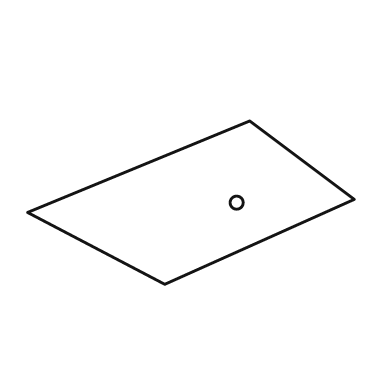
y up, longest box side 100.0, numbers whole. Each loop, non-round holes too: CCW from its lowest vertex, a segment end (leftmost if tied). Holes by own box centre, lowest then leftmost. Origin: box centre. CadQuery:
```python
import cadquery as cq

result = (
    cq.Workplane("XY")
    .moveTo(-8.0, -25.0)
    .lineTo(50.0, 1.0)
    .lineTo(18.0, 25.0)
    .lineTo(-50.0, -3.0)
    .close()
    .moveTo(14.0, 0.0)
    .circle(2.0)
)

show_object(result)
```